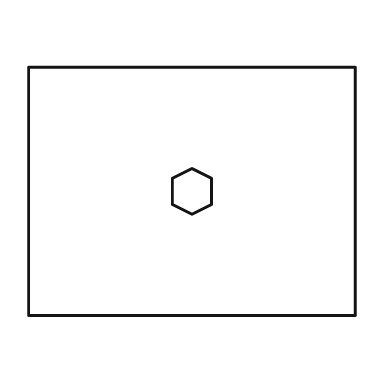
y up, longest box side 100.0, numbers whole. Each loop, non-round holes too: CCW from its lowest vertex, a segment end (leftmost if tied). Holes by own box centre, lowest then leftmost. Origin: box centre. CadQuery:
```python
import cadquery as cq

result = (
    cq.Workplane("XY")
    .moveTo(-50.0, -38.0)
    .lineTo(50.0, -38.0)
    .lineTo(50.0, 38.0)
    .lineTo(-50.0, 38.0)
    .close()
    .moveTo(0.0, -7.0)
    .lineTo(6.0, -4.0)
    .lineTo(6.0, 4.0)
    .lineTo(0.0, 7.0)
    .lineTo(-6.0, 4.0)
    .lineTo(-6.0, -4.0)
    .close()
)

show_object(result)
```